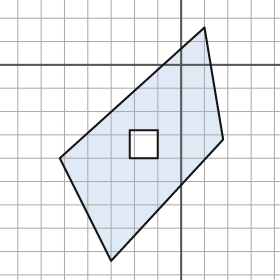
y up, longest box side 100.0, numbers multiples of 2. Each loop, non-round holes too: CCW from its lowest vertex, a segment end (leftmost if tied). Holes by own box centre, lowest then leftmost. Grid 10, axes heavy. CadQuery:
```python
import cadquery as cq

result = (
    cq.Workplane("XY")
    .moveTo(-30.0, -84.0)
    .lineTo(18.0, -32.0)
    .lineTo(10.0, 16.0)
    .lineTo(-52.0, -40.0)
    .close()
    .moveTo(-22.0, -40.0)
    .lineTo(-10.0, -40.0)
    .lineTo(-10.0, -28.0)
    .lineTo(-22.0, -28.0)
    .close()
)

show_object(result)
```